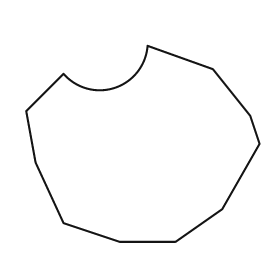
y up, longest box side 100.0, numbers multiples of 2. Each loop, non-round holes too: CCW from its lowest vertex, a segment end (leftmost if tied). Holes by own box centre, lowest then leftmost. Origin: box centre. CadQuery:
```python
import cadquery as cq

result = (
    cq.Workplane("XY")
    .moveTo(-10.0, -42.0)
    .lineTo(14.0, -42.0)
    .lineTo(34.0, -28.0)
    .lineTo(50.0, 0.0)
    .lineTo(46.0, 12.0)
    .lineTo(30.0, 32.0)
    .lineTo(2.0, 42.0)
    .threePointArc((-12.0, 24.0), (-34.0, 30.0))
    .lineTo(-50.0, 14.0)
    .lineTo(-46.0, -8.0)
    .lineTo(-34.0, -34.0)
    .close()
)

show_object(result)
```